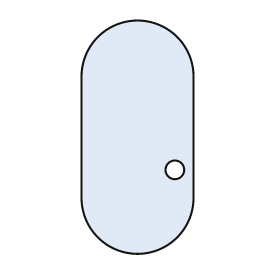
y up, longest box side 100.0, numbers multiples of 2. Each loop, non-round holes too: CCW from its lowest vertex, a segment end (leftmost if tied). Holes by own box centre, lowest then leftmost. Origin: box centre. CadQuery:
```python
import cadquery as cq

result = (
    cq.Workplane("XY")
    .moveTo(-24.0, -26.0)
    .threePointArc((0.0, -50.0), (24.0, -26.0))
    .lineTo(24.0, 26.0)
    .threePointArc((0.0, 50.0), (-24.0, 26.0))
    .close()
    .moveTo(16.0, -14.0)
    .circle(4.0)
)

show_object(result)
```